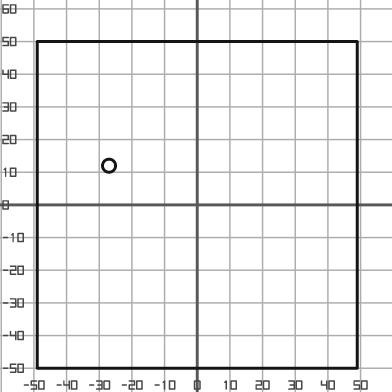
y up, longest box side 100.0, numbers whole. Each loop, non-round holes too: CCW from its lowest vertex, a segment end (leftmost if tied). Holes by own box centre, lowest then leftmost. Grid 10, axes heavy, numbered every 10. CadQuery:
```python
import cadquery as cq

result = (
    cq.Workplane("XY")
    .moveTo(-49.0, -50.0)
    .lineTo(49.0, -50.0)
    .lineTo(49.0, 50.0)
    .lineTo(-49.0, 50.0)
    .close()
    .moveTo(-27.0, 12.0)
    .circle(2.0)
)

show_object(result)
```